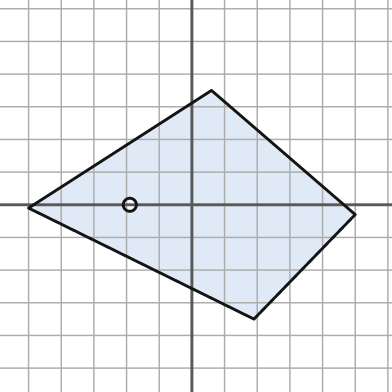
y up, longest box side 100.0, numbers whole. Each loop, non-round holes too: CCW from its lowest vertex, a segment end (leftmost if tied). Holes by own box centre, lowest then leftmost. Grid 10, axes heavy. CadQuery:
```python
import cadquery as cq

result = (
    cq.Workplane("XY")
    .moveTo(19.0, -35.0)
    .lineTo(50.0, -3.0)
    .lineTo(6.0, 35.0)
    .lineTo(-50.0, -1.0)
    .close()
    .moveTo(-19.0, 0.0)
    .circle(2.0)
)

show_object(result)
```